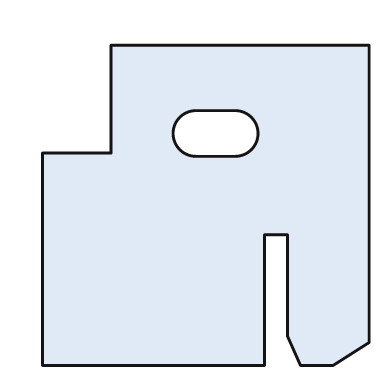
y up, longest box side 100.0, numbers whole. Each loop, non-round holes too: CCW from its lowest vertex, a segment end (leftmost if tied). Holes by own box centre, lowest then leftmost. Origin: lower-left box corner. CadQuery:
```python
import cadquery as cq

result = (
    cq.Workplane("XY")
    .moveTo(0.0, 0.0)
    .lineTo(68.0, 0.0)
    .lineTo(68.0, 40.0)
    .lineTo(75.0, 40.0)
    .lineTo(75.0, 9.0)
    .lineTo(79.0, 0.0)
    .lineTo(89.0, 0.0)
    .lineTo(100.0, 7.0)
    .lineTo(100.0, 98.0)
    .lineTo(21.0, 98.0)
    .lineTo(21.0, 65.0)
    .lineTo(0.0, 65.0)
    .close()
    .moveTo(47.0, 64.0)
    .lineTo(59.0, 64.0)
    .threePointArc((66.0, 71.0), (59.0, 78.0))
    .lineTo(47.0, 78.0)
    .threePointArc((40.0, 71.0), (47.0, 64.0))
    .close()
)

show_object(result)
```